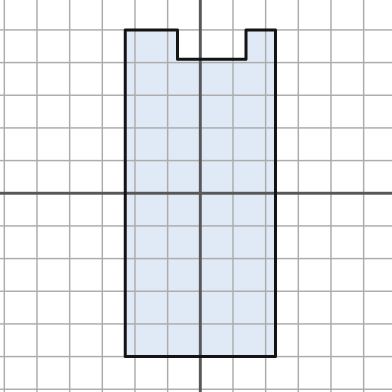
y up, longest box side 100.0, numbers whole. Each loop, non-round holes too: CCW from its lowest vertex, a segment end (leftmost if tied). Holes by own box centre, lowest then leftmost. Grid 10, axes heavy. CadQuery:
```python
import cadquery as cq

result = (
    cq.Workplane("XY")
    .moveTo(-23.0, -50.0)
    .lineTo(23.0, -50.0)
    .lineTo(23.0, 50.0)
    .lineTo(14.0, 50.0)
    .lineTo(14.0, 41.0)
    .lineTo(-7.0, 41.0)
    .lineTo(-7.0, 50.0)
    .lineTo(-23.0, 50.0)
    .close()
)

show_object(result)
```